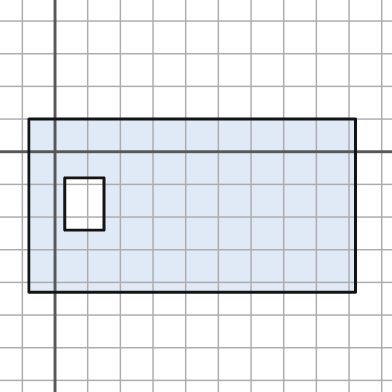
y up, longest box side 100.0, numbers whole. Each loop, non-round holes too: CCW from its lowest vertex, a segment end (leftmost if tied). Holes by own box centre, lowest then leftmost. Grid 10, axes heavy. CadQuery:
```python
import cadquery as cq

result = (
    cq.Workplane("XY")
    .moveTo(-8.0, -43.0)
    .lineTo(92.0, -43.0)
    .lineTo(92.0, 10.0)
    .lineTo(-8.0, 10.0)
    .close()
    .moveTo(3.0, -24.0)
    .lineTo(15.0, -24.0)
    .lineTo(15.0, -8.0)
    .lineTo(3.0, -8.0)
    .close()
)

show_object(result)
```